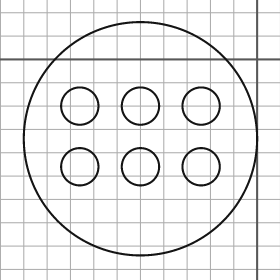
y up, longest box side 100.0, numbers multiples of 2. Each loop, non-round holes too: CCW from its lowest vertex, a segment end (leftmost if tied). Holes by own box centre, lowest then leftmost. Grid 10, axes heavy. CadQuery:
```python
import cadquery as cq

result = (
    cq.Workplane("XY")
    .moveTo(-50.0, -34.0)
    .circle(50.0)
    .moveTo(-76.0, -46.0)
    .circle(8.0)
    .moveTo(-50.0, -46.0)
    .circle(8.0)
    .moveTo(-24.0, -46.0)
    .circle(8.0)
    .moveTo(-76.0, -20.0)
    .circle(8.0)
    .moveTo(-50.0, -20.0)
    .circle(8.0)
    .moveTo(-24.0, -20.0)
    .circle(8.0)
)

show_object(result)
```